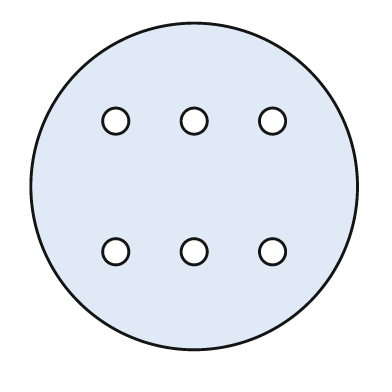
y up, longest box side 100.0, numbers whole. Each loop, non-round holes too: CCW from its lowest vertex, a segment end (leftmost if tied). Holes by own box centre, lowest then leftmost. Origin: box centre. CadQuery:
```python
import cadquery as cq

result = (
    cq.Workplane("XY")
    .moveTo(0.0, 0.0)
    .circle(50.0)
    .moveTo(-24.0, -20.0)
    .circle(4.0)
    .moveTo(0.0, -20.0)
    .circle(4.0)
    .moveTo(24.0, -20.0)
    .circle(4.0)
    .moveTo(-24.0, 20.0)
    .circle(4.0)
    .moveTo(0.0, 20.0)
    .circle(4.0)
    .moveTo(24.0, 20.0)
    .circle(4.0)
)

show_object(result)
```